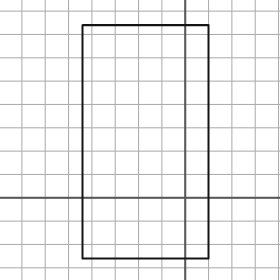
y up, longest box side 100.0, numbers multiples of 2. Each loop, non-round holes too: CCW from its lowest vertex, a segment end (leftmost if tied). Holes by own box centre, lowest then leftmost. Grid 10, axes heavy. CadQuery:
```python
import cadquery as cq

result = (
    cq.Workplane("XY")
    .moveTo(-44.0, -26.0)
    .lineTo(10.0, -26.0)
    .lineTo(10.0, 74.0)
    .lineTo(-44.0, 74.0)
    .close()
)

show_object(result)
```